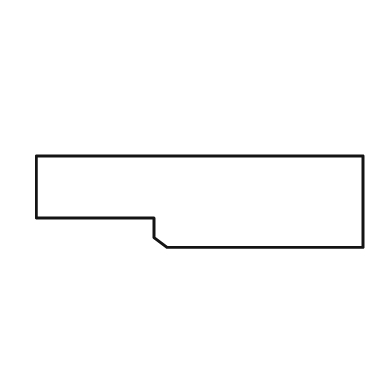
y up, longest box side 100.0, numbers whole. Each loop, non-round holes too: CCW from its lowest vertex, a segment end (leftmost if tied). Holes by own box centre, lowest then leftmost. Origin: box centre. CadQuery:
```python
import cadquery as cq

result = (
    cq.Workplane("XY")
    .moveTo(-10.0, -14.0)
    .lineTo(50.0, -14.0)
    .lineTo(50.0, 14.0)
    .lineTo(-50.0, 14.0)
    .lineTo(-50.0, -5.0)
    .lineTo(-14.0, -5.0)
    .lineTo(-14.0, -11.0)
    .close()
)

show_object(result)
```